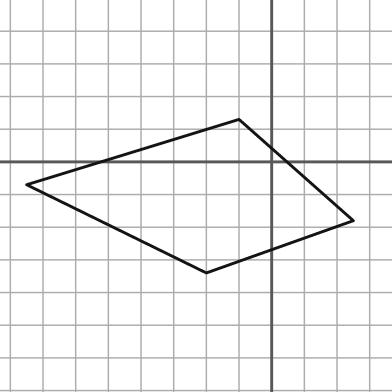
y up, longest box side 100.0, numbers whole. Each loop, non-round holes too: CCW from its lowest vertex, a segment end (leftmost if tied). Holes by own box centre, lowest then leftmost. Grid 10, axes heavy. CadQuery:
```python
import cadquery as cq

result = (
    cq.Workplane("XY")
    .moveTo(-20.0, -34.0)
    .lineTo(25.0, -18.0)
    .lineTo(-10.0, 13.0)
    .lineTo(-75.0, -7.0)
    .close()
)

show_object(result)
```